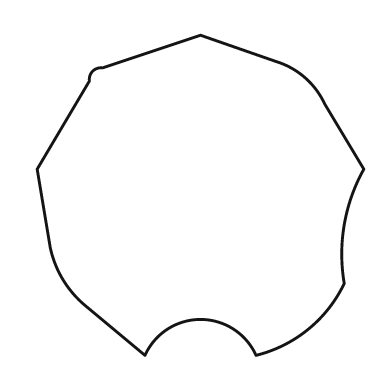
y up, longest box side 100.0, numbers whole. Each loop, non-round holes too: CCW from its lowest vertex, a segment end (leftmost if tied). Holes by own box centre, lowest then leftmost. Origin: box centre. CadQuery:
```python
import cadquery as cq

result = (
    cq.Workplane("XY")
    .moveTo(-17.0, -49.0)
    .threePointArc((0.0, -38.0), (17.0, -49.0))
    .threePointArc((33.0, -41.0), (44.0, -27.0))
    .threePointArc((44.0, -9.0), (50.0, 8.0))
    .lineTo(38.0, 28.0)
    .threePointArc((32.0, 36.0), (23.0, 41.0))
    .lineTo(0.0, 49.0)
    .lineTo(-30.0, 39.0)
    .threePointArc((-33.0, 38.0), (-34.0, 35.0))
    .lineTo(-50.0, 8.0)
    .lineTo(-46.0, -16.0)
    .threePointArc((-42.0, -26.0), (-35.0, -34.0))
    .close()
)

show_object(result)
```